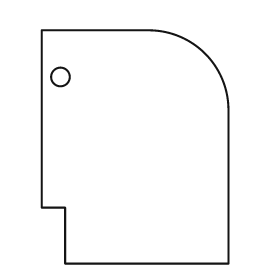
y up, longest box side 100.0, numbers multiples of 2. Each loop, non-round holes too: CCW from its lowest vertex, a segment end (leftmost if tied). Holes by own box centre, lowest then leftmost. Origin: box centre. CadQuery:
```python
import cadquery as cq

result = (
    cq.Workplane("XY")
    .moveTo(-30.0, -50.0)
    .lineTo(40.0, -50.0)
    .lineTo(40.0, 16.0)
    .threePointArc((30.0, 40.0), (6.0, 50.0))
    .lineTo(-40.0, 50.0)
    .lineTo(-40.0, -26.0)
    .lineTo(-30.0, -26.0)
    .close()
    .moveTo(-32.0, 30.0)
    .circle(4.0)
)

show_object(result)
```